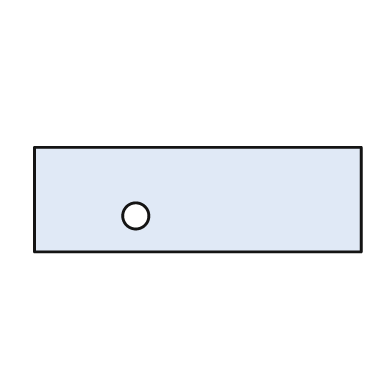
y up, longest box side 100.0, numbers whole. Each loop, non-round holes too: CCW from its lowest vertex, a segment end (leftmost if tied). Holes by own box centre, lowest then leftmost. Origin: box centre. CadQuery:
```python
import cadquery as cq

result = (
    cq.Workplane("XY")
    .moveTo(-50.0, -16.0)
    .lineTo(50.0, -16.0)
    .lineTo(50.0, 16.0)
    .lineTo(-50.0, 16.0)
    .close()
    .moveTo(-19.0, -5.0)
    .circle(4.0)
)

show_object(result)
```